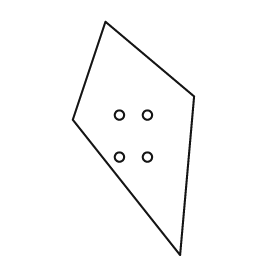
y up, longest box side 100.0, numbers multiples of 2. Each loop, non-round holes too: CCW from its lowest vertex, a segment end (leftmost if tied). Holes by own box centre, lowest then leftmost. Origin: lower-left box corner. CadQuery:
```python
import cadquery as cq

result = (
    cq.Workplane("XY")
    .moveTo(46.0, 0.0)
    .lineTo(52.0, 68.0)
    .lineTo(14.0, 100.0)
    .lineTo(0.0, 58.0)
    .close()
    .moveTo(20.0, 42.0)
    .circle(2.0)
    .moveTo(32.0, 42.0)
    .circle(2.0)
    .moveTo(20.0, 60.0)
    .circle(2.0)
    .moveTo(32.0, 60.0)
    .circle(2.0)
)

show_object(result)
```